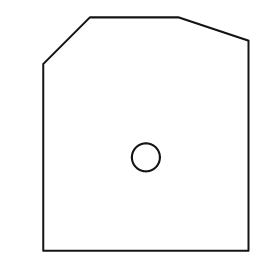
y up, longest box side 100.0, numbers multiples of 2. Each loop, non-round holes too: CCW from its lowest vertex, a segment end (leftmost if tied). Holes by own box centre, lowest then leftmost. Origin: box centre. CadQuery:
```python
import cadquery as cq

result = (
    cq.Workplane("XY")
    .moveTo(-44.0, -50.0)
    .lineTo(44.0, -50.0)
    .lineTo(44.0, 40.0)
    .lineTo(14.0, 50.0)
    .lineTo(-24.0, 50.0)
    .lineTo(-44.0, 30.0)
    .close()
    .moveTo(0.0, -10.0)
    .circle(6.0)
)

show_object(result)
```